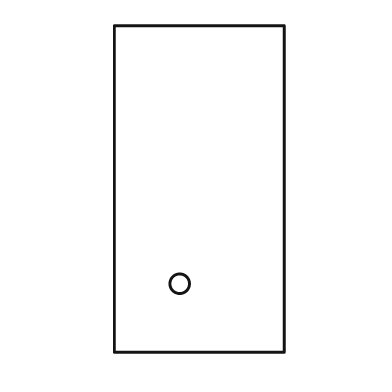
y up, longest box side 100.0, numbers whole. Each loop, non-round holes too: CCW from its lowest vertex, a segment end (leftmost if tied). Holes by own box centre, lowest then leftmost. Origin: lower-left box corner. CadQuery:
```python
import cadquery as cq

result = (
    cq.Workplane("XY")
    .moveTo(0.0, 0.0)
    .lineTo(52.0, 0.0)
    .lineTo(52.0, 100.0)
    .lineTo(0.0, 100.0)
    .close()
    .moveTo(20.0, 21.0)
    .circle(3.0)
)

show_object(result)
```